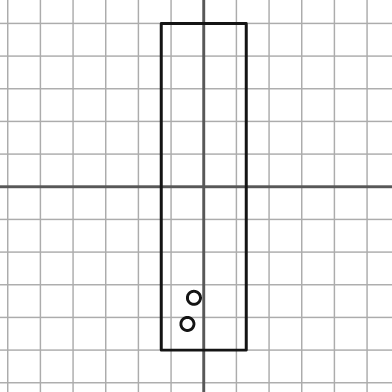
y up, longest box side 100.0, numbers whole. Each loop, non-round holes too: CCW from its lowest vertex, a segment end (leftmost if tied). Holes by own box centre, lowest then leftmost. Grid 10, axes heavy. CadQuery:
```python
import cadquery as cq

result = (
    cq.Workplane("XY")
    .moveTo(-13.0, -50.0)
    .lineTo(13.0, -50.0)
    .lineTo(13.0, 50.0)
    .lineTo(-13.0, 50.0)
    .close()
    .moveTo(-5.0, -42.0)
    .circle(2.0)
    .moveTo(-3.0, -34.0)
    .circle(2.0)
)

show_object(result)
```